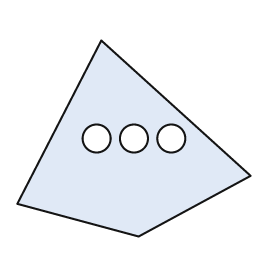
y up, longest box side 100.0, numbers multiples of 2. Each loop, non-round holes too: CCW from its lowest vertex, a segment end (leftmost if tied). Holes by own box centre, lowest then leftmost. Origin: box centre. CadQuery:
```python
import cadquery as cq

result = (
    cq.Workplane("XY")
    .moveTo(2.0, -42.0)
    .lineTo(50.0, -16.0)
    .lineTo(-14.0, 42.0)
    .lineTo(-50.0, -28.0)
    .close()
    .moveTo(-16.0, 0.0)
    .circle(6.0)
    .moveTo(0.0, 0.0)
    .circle(6.0)
    .moveTo(16.0, 0.0)
    .circle(6.0)
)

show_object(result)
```